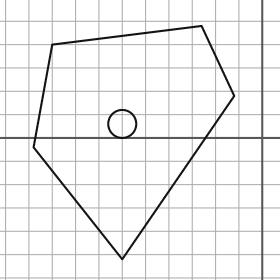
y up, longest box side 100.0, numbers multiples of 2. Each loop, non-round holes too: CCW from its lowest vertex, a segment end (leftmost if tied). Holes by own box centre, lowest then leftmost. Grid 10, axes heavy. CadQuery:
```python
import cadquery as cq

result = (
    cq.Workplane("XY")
    .moveTo(-60.0, -52.0)
    .lineTo(-12.0, 18.0)
    .lineTo(-26.0, 48.0)
    .lineTo(-90.0, 40.0)
    .lineTo(-98.0, -4.0)
    .close()
    .moveTo(-60.0, 6.0)
    .circle(6.0)
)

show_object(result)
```